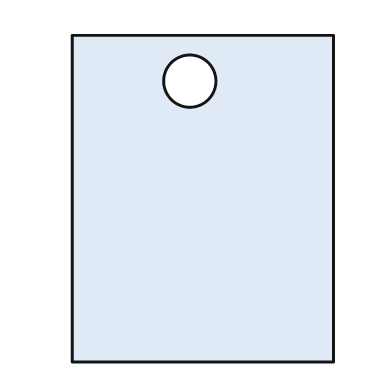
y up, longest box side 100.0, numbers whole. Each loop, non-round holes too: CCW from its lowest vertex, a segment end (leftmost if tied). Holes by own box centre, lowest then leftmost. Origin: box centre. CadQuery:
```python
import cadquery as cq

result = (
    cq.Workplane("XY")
    .moveTo(-40.0, -50.0)
    .lineTo(40.0, -50.0)
    .lineTo(40.0, 50.0)
    .lineTo(-40.0, 50.0)
    .close()
    .moveTo(-4.0, 36.0)
    .circle(8.0)
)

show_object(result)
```